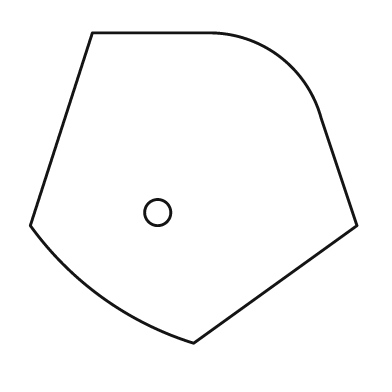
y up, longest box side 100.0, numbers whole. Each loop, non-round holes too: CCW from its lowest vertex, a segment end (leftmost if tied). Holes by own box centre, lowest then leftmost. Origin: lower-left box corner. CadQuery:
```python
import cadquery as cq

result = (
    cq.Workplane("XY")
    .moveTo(50.0, 0.0)
    .lineTo(100.0, 36.0)
    .lineTo(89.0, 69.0)
    .threePointArc((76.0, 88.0), (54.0, 95.0))
    .lineTo(19.0, 95.0)
    .lineTo(0.0, 36.0)
    .threePointArc((22.0, 14.0), (50.0, 0.0))
    .close()
    .moveTo(39.0, 40.0)
    .circle(4.0)
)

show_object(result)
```